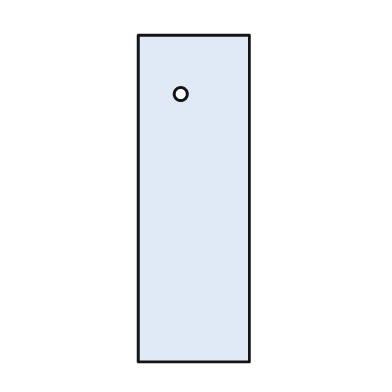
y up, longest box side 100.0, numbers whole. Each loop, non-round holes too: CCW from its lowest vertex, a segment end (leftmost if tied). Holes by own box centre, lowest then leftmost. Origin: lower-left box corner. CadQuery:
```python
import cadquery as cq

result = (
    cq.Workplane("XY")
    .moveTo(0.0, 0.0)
    .lineTo(34.0, 0.0)
    .lineTo(34.0, 100.0)
    .lineTo(0.0, 100.0)
    .close()
    .moveTo(13.0, 82.0)
    .circle(2.0)
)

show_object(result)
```